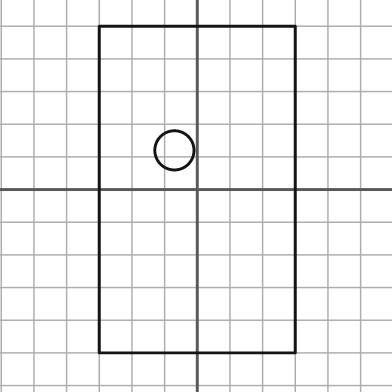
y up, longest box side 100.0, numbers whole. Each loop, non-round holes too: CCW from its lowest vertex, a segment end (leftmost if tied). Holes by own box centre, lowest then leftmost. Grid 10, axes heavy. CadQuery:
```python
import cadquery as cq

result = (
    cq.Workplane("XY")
    .moveTo(-30.0, -50.0)
    .lineTo(30.0, -50.0)
    .lineTo(30.0, 50.0)
    .lineTo(-30.0, 50.0)
    .close()
    .moveTo(-7.0, 12.0)
    .circle(6.0)
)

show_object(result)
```